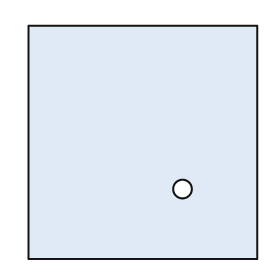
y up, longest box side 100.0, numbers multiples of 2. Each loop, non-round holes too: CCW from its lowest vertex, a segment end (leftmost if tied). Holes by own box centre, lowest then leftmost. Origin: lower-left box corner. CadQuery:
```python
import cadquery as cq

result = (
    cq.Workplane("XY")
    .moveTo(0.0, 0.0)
    .lineTo(98.0, 0.0)
    .lineTo(98.0, 100.0)
    .lineTo(0.0, 100.0)
    .close()
    .moveTo(66.0, 30.0)
    .circle(4.0)
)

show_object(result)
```